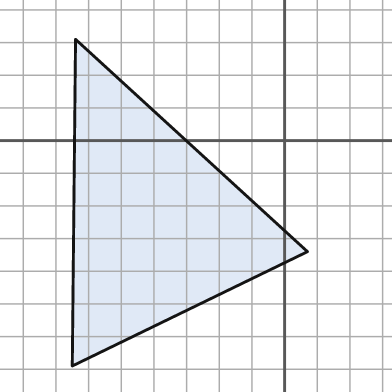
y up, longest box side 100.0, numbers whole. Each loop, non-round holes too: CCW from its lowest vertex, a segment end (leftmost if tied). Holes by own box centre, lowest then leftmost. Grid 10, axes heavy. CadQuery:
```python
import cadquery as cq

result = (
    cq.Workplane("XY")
    .moveTo(-65.0, -69.0)
    .lineTo(7.0, -34.0)
    .lineTo(-64.0, 31.0)
    .close()
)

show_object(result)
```